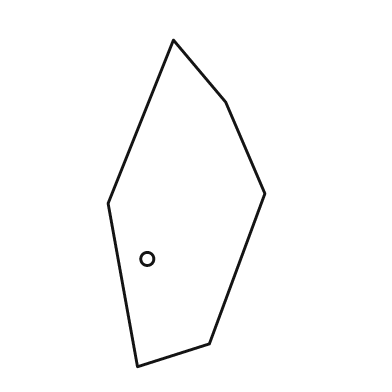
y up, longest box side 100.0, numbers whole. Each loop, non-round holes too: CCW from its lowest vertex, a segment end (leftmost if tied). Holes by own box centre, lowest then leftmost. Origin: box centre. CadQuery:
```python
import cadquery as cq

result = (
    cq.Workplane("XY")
    .moveTo(-15.0, -50.0)
    .lineTo(7.0, -43.0)
    .lineTo(24.0, 3.0)
    .lineTo(12.0, 31.0)
    .lineTo(-4.0, 50.0)
    .lineTo(-24.0, 0.0)
    .close()
    .moveTo(-12.0, -17.0)
    .circle(2.0)
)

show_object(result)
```